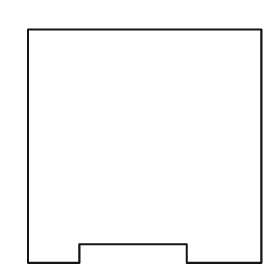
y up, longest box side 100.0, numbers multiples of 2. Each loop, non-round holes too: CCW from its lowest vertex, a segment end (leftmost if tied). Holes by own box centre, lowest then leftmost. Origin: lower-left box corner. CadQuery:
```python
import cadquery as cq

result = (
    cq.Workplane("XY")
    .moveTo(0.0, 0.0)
    .lineTo(22.0, 0.0)
    .lineTo(22.0, 8.0)
    .lineTo(68.0, 8.0)
    .lineTo(68.0, 0.0)
    .lineTo(100.0, 0.0)
    .lineTo(100.0, 100.0)
    .lineTo(0.0, 100.0)
    .close()
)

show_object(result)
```